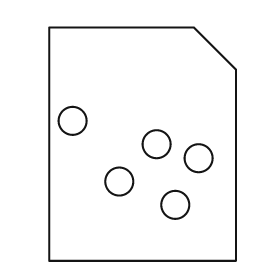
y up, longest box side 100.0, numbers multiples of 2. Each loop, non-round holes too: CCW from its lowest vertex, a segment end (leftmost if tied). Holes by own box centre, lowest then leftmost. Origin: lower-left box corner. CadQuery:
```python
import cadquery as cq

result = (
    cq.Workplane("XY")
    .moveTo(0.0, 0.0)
    .lineTo(80.0, 0.0)
    .lineTo(80.0, 82.0)
    .lineTo(62.0, 100.0)
    .lineTo(0.0, 100.0)
    .close()
    .moveTo(54.0, 24.0)
    .circle(6.0)
    .moveTo(30.0, 34.0)
    .circle(6.0)
    .moveTo(64.0, 44.0)
    .circle(6.0)
    .moveTo(46.0, 50.0)
    .circle(6.0)
    .moveTo(10.0, 60.0)
    .circle(6.0)
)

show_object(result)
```